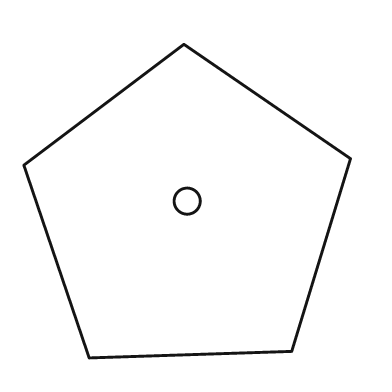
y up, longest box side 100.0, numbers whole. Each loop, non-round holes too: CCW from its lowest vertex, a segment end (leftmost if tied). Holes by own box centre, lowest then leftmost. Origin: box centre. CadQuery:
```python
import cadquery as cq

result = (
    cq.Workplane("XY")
    .moveTo(-30.0, -48.0)
    .lineTo(32.0, -46.0)
    .lineTo(50.0, 13.0)
    .lineTo(-1.0, 48.0)
    .lineTo(-50.0, 11.0)
    .close()
    .moveTo(0.0, 0.0)
    .circle(4.0)
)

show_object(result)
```